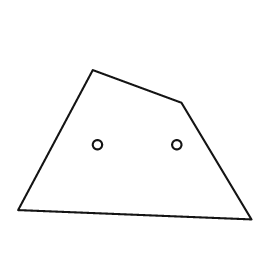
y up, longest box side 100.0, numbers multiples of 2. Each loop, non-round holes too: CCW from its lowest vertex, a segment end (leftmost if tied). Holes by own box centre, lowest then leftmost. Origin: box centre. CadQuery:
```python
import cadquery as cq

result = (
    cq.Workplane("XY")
    .moveTo(50.0, -32.0)
    .lineTo(20.0, 18.0)
    .lineTo(-18.0, 32.0)
    .lineTo(-50.0, -28.0)
    .close()
    .moveTo(-16.0, 0.0)
    .circle(2.0)
    .moveTo(18.0, 0.0)
    .circle(2.0)
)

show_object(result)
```